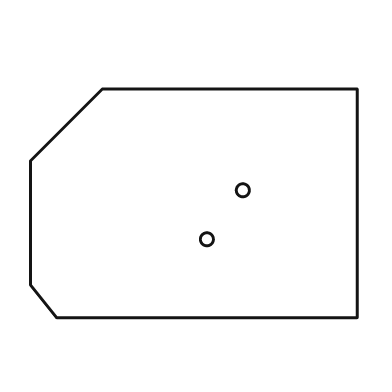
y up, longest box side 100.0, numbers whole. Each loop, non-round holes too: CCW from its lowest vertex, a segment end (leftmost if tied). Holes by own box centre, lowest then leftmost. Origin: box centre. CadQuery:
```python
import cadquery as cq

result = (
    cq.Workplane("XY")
    .moveTo(-42.0, -35.0)
    .lineTo(50.0, -35.0)
    .lineTo(50.0, 35.0)
    .lineTo(-28.0, 35.0)
    .lineTo(-50.0, 13.0)
    .lineTo(-50.0, -25.0)
    .close()
    .moveTo(4.0, -11.0)
    .circle(2.0)
    .moveTo(15.0, 4.0)
    .circle(2.0)
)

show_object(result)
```